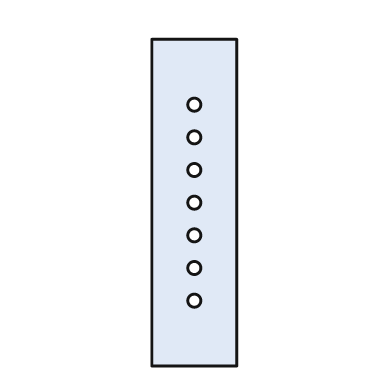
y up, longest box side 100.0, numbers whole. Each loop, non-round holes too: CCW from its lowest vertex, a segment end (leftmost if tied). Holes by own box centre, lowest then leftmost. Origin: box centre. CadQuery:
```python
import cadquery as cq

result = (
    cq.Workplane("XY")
    .moveTo(-13.0, -50.0)
    .lineTo(13.0, -50.0)
    .lineTo(13.0, 50.0)
    .lineTo(-13.0, 50.0)
    .close()
    .moveTo(0.0, -30.0)
    .circle(2.0)
    .moveTo(0.0, -20.0)
    .circle(2.0)
    .moveTo(0.0, -10.0)
    .circle(2.0)
    .moveTo(0.0, 0.0)
    .circle(2.0)
    .moveTo(0.0, 10.0)
    .circle(2.0)
    .moveTo(0.0, 20.0)
    .circle(2.0)
    .moveTo(0.0, 30.0)
    .circle(2.0)
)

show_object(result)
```